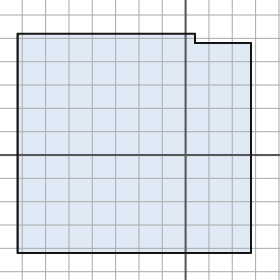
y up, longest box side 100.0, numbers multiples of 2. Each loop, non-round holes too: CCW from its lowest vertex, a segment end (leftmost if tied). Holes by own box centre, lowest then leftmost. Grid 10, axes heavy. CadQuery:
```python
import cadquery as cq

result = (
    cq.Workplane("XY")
    .moveTo(-72.0, -42.0)
    .lineTo(28.0, -42.0)
    .lineTo(28.0, 48.0)
    .lineTo(4.0, 48.0)
    .lineTo(4.0, 52.0)
    .lineTo(-72.0, 52.0)
    .close()
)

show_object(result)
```